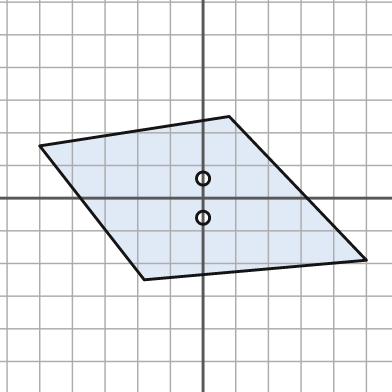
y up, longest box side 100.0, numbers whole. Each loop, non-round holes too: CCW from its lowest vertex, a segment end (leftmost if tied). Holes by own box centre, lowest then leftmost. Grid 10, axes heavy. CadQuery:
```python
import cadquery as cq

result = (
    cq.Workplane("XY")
    .moveTo(-18.0, -25.0)
    .lineTo(50.0, -19.0)
    .lineTo(8.0, 25.0)
    .lineTo(-50.0, 16.0)
    .close()
    .moveTo(0.0, -6.0)
    .circle(2.0)
    .moveTo(0.0, 6.0)
    .circle(2.0)
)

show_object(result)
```